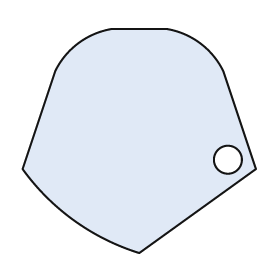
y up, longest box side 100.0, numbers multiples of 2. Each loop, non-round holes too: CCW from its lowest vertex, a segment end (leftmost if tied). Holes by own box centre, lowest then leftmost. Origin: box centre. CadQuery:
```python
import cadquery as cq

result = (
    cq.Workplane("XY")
    .moveTo(0.0, -48.0)
    .lineTo(50.0, -12.0)
    .lineTo(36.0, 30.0)
    .threePointArc((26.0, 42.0), (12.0, 48.0))
    .lineTo(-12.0, 48.0)
    .threePointArc((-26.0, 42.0), (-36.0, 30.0))
    .lineTo(-50.0, -12.0)
    .threePointArc((-28.0, -34.0), (0.0, -48.0))
    .close()
    .moveTo(38.0, -8.0)
    .circle(6.0)
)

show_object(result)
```